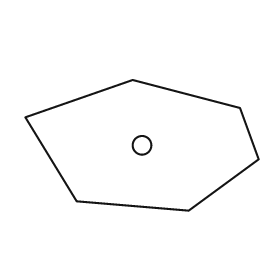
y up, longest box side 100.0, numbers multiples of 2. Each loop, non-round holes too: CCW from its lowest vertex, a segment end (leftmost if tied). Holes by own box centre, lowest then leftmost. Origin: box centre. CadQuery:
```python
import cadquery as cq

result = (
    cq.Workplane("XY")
    .moveTo(20.0, -28.0)
    .lineTo(50.0, -6.0)
    .lineTo(42.0, 16.0)
    .lineTo(-4.0, 28.0)
    .lineTo(-50.0, 12.0)
    .lineTo(-28.0, -24.0)
    .close()
    .moveTo(0.0, 0.0)
    .circle(4.0)
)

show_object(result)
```